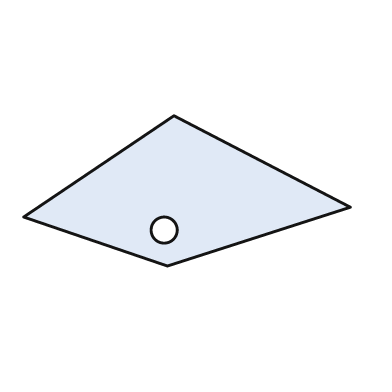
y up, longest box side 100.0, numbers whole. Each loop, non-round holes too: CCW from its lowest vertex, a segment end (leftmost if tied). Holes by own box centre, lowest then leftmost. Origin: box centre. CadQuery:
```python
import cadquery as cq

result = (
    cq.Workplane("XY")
    .moveTo(-6.0, -23.0)
    .lineTo(50.0, -5.0)
    .lineTo(-4.0, 23.0)
    .lineTo(-50.0, -8.0)
    .close()
    .moveTo(-7.0, -12.0)
    .circle(4.0)
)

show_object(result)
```